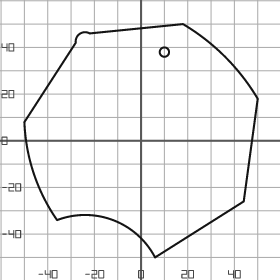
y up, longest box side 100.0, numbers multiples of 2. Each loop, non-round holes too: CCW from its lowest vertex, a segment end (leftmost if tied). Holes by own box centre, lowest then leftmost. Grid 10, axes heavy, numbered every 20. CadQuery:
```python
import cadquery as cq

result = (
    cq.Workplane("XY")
    .moveTo(6.0, -50.0)
    .lineTo(44.0, -26.0)
    .lineTo(50.0, 18.0)
    .threePointArc((36.0, 36.0), (18.0, 50.0))
    .lineTo(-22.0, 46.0)
    .threePointArc((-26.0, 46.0), (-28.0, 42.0))
    .lineTo(-50.0, 8.0)
    .threePointArc((-46.0, -14.0), (-36.0, -34.0))
    .threePointArc((-12.0, -34.0), (6.0, -50.0))
    .close()
    .moveTo(10.0, 38.0)
    .circle(2.0)
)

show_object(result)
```